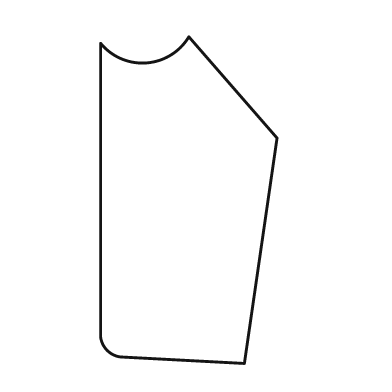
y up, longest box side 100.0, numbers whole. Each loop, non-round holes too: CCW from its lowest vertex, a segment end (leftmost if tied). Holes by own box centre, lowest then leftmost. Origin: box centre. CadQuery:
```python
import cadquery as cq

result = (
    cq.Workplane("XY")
    .moveTo(17.0, -50.0)
    .lineTo(27.0, 19.0)
    .lineTo(0.0, 50.0)
    .threePointArc((-13.0, 42.0), (-27.0, 48.0))
    .lineTo(-27.0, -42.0)
    .threePointArc((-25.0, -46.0), (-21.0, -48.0))
    .close()
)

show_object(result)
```